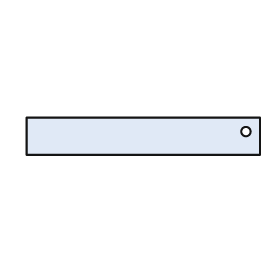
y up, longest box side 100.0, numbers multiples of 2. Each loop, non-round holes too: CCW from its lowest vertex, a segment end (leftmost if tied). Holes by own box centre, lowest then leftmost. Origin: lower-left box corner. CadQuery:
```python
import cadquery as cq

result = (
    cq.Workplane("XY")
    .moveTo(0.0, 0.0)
    .lineTo(100.0, 0.0)
    .lineTo(100.0, 16.0)
    .lineTo(0.0, 16.0)
    .close()
    .moveTo(94.0, 10.0)
    .circle(2.0)
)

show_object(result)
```